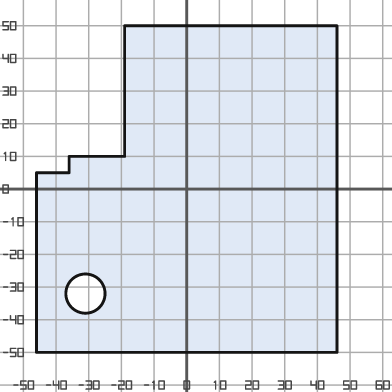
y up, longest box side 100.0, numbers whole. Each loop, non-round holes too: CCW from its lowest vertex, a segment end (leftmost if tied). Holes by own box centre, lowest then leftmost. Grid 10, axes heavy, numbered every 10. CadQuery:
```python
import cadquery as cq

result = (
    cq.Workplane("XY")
    .moveTo(-46.0, -50.0)
    .lineTo(46.0, -50.0)
    .lineTo(46.0, 50.0)
    .lineTo(-19.0, 50.0)
    .lineTo(-19.0, 10.0)
    .lineTo(-36.0, 10.0)
    .lineTo(-36.0, 5.0)
    .lineTo(-46.0, 5.0)
    .close()
    .moveTo(-31.0, -32.0)
    .circle(6.0)
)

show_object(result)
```